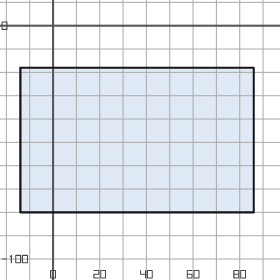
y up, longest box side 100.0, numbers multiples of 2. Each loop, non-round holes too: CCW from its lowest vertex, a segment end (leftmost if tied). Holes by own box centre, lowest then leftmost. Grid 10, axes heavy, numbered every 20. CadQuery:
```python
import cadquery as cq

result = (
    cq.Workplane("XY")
    .moveTo(-14.0, -80.0)
    .lineTo(86.0, -80.0)
    .lineTo(86.0, -18.0)
    .lineTo(-14.0, -18.0)
    .close()
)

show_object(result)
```